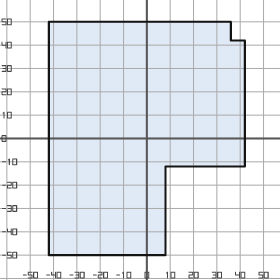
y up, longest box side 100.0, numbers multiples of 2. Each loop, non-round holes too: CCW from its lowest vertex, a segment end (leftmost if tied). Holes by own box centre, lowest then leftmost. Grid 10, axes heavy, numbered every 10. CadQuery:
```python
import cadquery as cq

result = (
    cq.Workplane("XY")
    .moveTo(-42.0, -50.0)
    .lineTo(8.0, -50.0)
    .lineTo(8.0, -12.0)
    .lineTo(42.0, -12.0)
    .lineTo(42.0, 42.0)
    .lineTo(36.0, 42.0)
    .lineTo(36.0, 50.0)
    .lineTo(-42.0, 50.0)
    .close()
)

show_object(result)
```